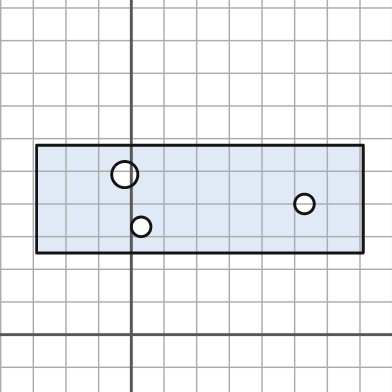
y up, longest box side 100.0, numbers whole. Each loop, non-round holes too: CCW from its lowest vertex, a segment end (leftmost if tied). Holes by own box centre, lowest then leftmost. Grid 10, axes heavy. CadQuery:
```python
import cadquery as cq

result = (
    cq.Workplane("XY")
    .moveTo(-29.0, 25.0)
    .lineTo(71.0, 25.0)
    .lineTo(71.0, 58.0)
    .lineTo(-29.0, 58.0)
    .close()
    .moveTo(3.0, 33.0)
    .circle(3.0)
    .moveTo(53.0, 40.0)
    .circle(3.0)
    .moveTo(-2.0, 49.0)
    .circle(4.0)
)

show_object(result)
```